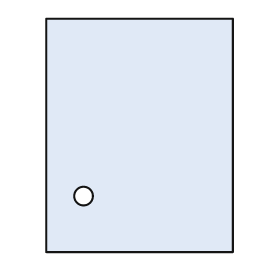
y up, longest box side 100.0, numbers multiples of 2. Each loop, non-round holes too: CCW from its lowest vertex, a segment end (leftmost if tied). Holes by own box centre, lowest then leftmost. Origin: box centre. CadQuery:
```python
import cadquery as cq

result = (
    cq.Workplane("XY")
    .moveTo(-40.0, -50.0)
    .lineTo(40.0, -50.0)
    .lineTo(40.0, 50.0)
    .lineTo(-40.0, 50.0)
    .close()
    .moveTo(-24.0, -26.0)
    .circle(4.0)
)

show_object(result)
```